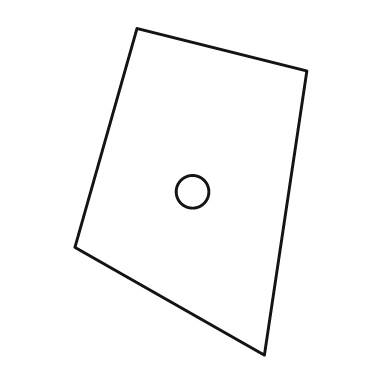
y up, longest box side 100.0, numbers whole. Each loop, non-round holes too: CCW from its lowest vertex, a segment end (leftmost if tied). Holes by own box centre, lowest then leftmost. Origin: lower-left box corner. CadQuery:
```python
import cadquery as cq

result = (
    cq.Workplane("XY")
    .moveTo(58.0, 0.0)
    .lineTo(71.0, 87.0)
    .lineTo(19.0, 100.0)
    .lineTo(0.0, 33.0)
    .close()
    .moveTo(36.0, 50.0)
    .circle(5.0)
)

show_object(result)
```